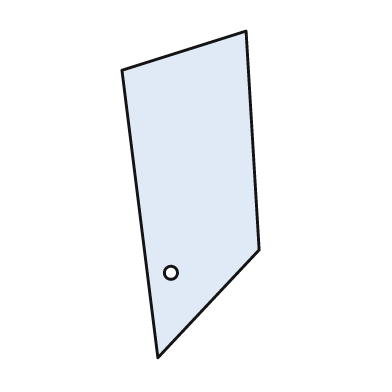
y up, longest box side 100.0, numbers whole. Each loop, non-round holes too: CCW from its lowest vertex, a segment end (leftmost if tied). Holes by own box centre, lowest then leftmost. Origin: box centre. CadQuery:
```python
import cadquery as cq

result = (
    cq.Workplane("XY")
    .moveTo(-10.0, -50.0)
    .lineTo(21.0, -17.0)
    .lineTo(17.0, 50.0)
    .lineTo(-21.0, 38.0)
    .close()
    .moveTo(-6.0, -24.0)
    .circle(2.0)
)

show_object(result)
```